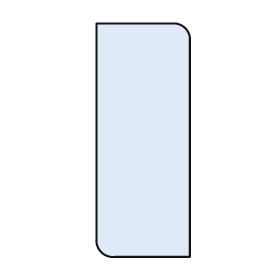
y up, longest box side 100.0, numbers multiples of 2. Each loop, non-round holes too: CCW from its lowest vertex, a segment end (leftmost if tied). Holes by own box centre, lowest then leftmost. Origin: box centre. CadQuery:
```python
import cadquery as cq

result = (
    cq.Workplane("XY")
    .moveTo(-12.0, -50.0)
    .lineTo(20.0, -50.0)
    .lineTo(20.0, 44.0)
    .threePointArc((18.0, 48.0), (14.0, 50.0))
    .lineTo(-20.0, 50.0)
    .lineTo(-20.0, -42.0)
    .threePointArc((-18.0, -48.0), (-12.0, -50.0))
    .close()
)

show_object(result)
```